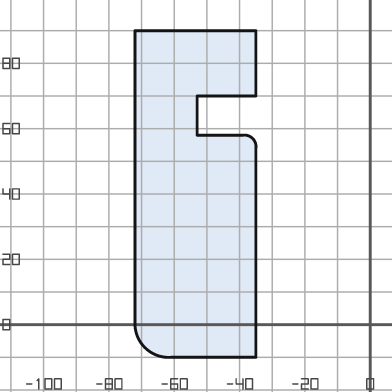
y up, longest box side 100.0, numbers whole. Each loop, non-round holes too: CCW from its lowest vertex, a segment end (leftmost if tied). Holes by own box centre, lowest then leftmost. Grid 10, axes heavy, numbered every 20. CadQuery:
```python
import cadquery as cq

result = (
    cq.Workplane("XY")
    .moveTo(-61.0, -10.0)
    .lineTo(-35.0, -10.0)
    .lineTo(-35.0, 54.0)
    .threePointArc((-36.0, 57.0), (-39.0, 58.0))
    .lineTo(-53.0, 58.0)
    .lineTo(-53.0, 70.0)
    .lineTo(-35.0, 70.0)
    .lineTo(-35.0, 90.0)
    .lineTo(-72.0, 90.0)
    .lineTo(-72.0, 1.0)
    .threePointArc((-69.0, -7.0), (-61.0, -10.0))
    .close()
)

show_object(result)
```